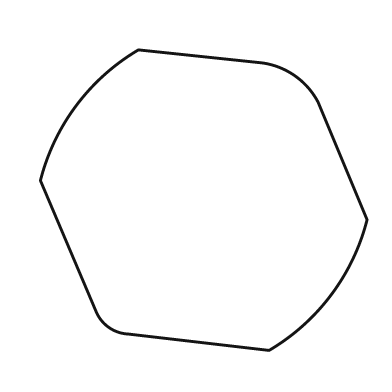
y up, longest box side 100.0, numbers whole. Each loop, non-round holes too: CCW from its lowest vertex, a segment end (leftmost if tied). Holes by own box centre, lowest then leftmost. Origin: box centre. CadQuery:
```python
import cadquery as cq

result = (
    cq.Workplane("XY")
    .moveTo(20.0, -46.0)
    .threePointArc((39.0, -29.0), (50.0, -6.0))
    .lineTo(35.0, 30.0)
    .threePointArc((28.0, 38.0), (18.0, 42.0))
    .lineTo(-20.0, 46.0)
    .threePointArc((-39.0, 29.0), (-50.0, 6.0))
    .lineTo(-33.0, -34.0)
    .threePointArc((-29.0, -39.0), (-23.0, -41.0))
    .close()
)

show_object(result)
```